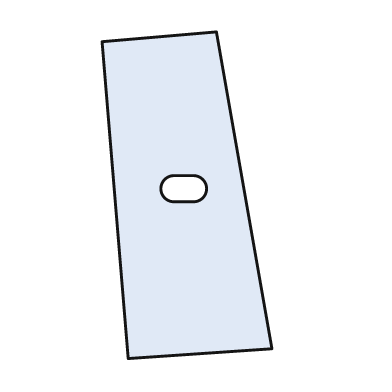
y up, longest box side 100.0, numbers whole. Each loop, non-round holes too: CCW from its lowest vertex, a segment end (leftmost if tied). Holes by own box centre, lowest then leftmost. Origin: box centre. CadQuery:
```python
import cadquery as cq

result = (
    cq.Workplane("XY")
    .moveTo(-18.0, -50.0)
    .lineTo(26.0, -47.0)
    .lineTo(9.0, 50.0)
    .lineTo(-26.0, 47.0)
    .close()
    .moveTo(-4.0, -2.0)
    .lineTo(2.0, -2.0)
    .threePointArc((6.0, 2.0), (2.0, 6.0))
    .lineTo(-4.0, 6.0)
    .threePointArc((-8.0, 2.0), (-4.0, -2.0))
    .close()
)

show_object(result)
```